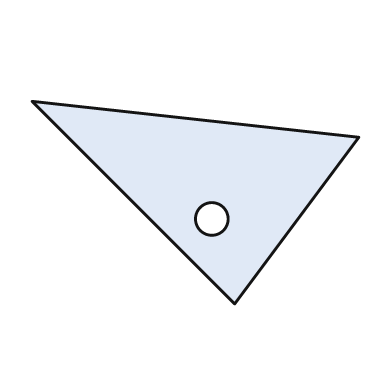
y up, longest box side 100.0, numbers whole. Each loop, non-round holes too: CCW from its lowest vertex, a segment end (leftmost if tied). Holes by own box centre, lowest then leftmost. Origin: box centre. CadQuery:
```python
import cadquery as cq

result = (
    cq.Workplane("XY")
    .moveTo(12.0, -31.0)
    .lineTo(50.0, 20.0)
    .lineTo(-50.0, 31.0)
    .close()
    .moveTo(5.0, -5.0)
    .circle(5.0)
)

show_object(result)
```